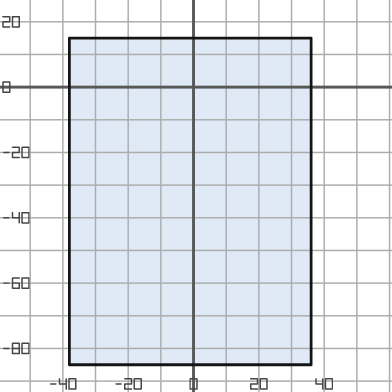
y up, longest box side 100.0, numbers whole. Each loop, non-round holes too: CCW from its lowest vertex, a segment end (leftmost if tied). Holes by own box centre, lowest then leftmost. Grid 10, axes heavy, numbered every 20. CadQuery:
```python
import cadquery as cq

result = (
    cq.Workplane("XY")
    .moveTo(-38.0, -85.0)
    .lineTo(36.0, -85.0)
    .lineTo(36.0, 15.0)
    .lineTo(-38.0, 15.0)
    .close()
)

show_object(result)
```